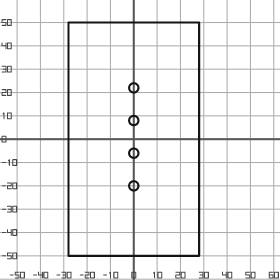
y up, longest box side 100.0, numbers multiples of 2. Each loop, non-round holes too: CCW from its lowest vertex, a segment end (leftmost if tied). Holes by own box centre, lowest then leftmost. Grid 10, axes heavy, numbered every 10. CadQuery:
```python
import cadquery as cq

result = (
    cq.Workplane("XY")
    .moveTo(-28.0, -50.0)
    .lineTo(28.0, -50.0)
    .lineTo(28.0, 50.0)
    .lineTo(-28.0, 50.0)
    .close()
    .moveTo(0.0, -20.0)
    .circle(2.0)
    .moveTo(0.0, -6.0)
    .circle(2.0)
    .moveTo(0.0, 8.0)
    .circle(2.0)
    .moveTo(0.0, 22.0)
    .circle(2.0)
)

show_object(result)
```